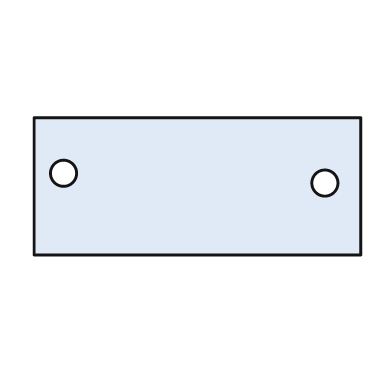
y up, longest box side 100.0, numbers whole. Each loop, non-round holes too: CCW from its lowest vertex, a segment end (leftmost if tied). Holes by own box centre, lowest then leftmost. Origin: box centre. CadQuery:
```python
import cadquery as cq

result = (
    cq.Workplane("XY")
    .moveTo(-50.0, -21.0)
    .lineTo(50.0, -21.0)
    .lineTo(50.0, 21.0)
    .lineTo(-50.0, 21.0)
    .close()
    .moveTo(39.0, 1.0)
    .circle(4.0)
    .moveTo(-41.0, 4.0)
    .circle(4.0)
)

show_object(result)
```